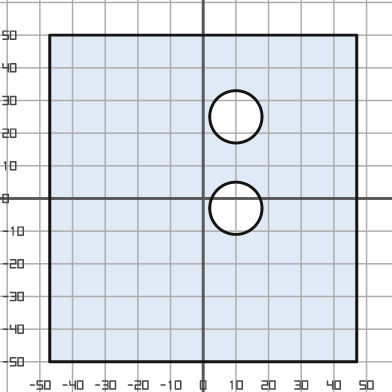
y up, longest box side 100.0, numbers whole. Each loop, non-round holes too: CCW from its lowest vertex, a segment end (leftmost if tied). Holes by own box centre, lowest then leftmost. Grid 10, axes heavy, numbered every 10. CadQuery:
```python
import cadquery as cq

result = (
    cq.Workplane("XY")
    .moveTo(-47.0, -50.0)
    .lineTo(47.0, -50.0)
    .lineTo(47.0, 50.0)
    .lineTo(-47.0, 50.0)
    .close()
    .moveTo(10.0, -3.0)
    .circle(8.0)
    .moveTo(10.0, 25.0)
    .circle(8.0)
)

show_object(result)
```